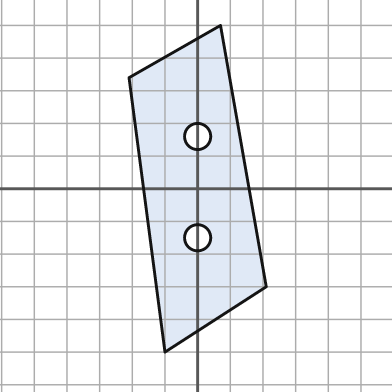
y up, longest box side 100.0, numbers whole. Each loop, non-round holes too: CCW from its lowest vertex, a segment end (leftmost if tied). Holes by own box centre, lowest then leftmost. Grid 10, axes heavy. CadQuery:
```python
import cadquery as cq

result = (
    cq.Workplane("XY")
    .moveTo(-10.0, -50.0)
    .lineTo(21.0, -30.0)
    .lineTo(7.0, 50.0)
    .lineTo(-21.0, 34.0)
    .close()
    .moveTo(0.0, -15.0)
    .circle(4.0)
    .moveTo(0.0, 16.0)
    .circle(4.0)
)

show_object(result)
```